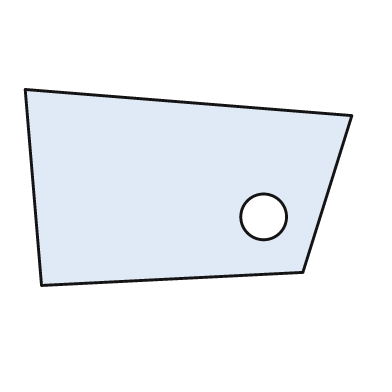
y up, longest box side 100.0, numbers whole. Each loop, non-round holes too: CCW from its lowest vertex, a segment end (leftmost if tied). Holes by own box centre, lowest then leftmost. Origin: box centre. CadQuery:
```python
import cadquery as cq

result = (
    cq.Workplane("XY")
    .moveTo(-45.0, -30.0)
    .lineTo(35.0, -26.0)
    .lineTo(50.0, 22.0)
    .lineTo(-50.0, 30.0)
    .close()
    .moveTo(23.0, -9.0)
    .circle(7.0)
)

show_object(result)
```